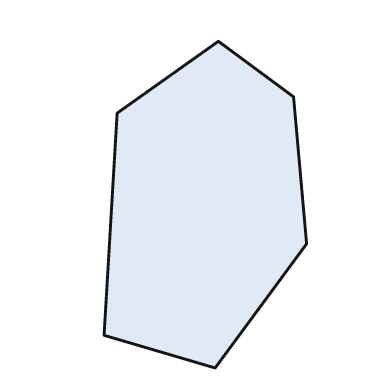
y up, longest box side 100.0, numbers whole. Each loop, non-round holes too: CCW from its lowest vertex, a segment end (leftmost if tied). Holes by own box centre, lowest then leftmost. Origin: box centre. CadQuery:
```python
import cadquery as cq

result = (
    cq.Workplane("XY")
    .moveTo(3.0, -50.0)
    .lineTo(31.0, -12.0)
    .lineTo(27.0, 33.0)
    .lineTo(4.0, 50.0)
    .lineTo(-27.0, 28.0)
    .lineTo(-31.0, -40.0)
    .close()
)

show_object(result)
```